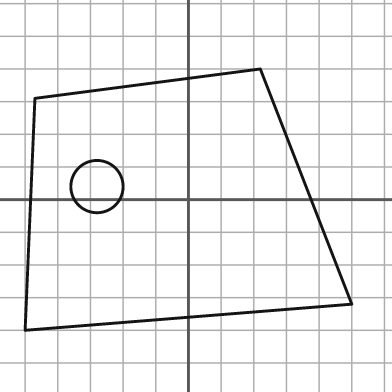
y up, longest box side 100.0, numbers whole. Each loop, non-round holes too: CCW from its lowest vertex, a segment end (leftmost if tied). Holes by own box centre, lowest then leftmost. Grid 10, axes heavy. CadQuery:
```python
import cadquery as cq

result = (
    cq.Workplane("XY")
    .moveTo(-50.0, -40.0)
    .lineTo(50.0, -32.0)
    .lineTo(22.0, 40.0)
    .lineTo(-47.0, 31.0)
    .close()
    .moveTo(-28.0, 4.0)
    .circle(8.0)
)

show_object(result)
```